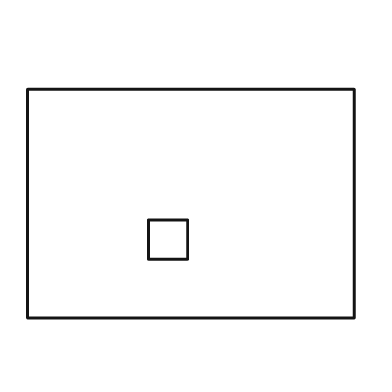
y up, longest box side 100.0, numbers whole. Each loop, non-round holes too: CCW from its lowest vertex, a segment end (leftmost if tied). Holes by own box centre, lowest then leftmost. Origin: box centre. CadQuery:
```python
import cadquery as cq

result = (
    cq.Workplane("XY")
    .moveTo(-50.0, -35.0)
    .lineTo(50.0, -35.0)
    .lineTo(50.0, 35.0)
    .lineTo(-50.0, 35.0)
    .close()
    .moveTo(-13.0, -17.0)
    .lineTo(-1.0, -17.0)
    .lineTo(-1.0, -5.0)
    .lineTo(-13.0, -5.0)
    .close()
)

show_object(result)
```